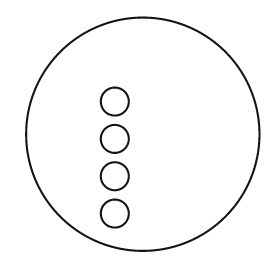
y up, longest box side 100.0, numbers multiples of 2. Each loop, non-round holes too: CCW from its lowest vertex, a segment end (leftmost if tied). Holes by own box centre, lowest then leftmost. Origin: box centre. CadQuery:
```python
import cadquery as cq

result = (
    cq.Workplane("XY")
    .moveTo(0.0, 0.0)
    .circle(50.0)
    .moveTo(-12.0, -34.0)
    .circle(6.0)
    .moveTo(-12.0, -18.0)
    .circle(6.0)
    .moveTo(-12.0, -2.0)
    .circle(6.0)
    .moveTo(-12.0, 14.0)
    .circle(6.0)
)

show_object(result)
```